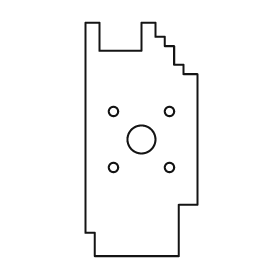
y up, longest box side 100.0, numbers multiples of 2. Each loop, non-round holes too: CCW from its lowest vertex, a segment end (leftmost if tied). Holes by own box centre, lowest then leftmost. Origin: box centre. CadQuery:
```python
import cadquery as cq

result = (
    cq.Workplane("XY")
    .moveTo(-20.0, -50.0)
    .lineTo(16.0, -50.0)
    .lineTo(16.0, -28.0)
    .lineTo(24.0, -28.0)
    .lineTo(24.0, 28.0)
    .lineTo(18.0, 28.0)
    .lineTo(18.0, 32.0)
    .lineTo(14.0, 32.0)
    .lineTo(14.0, 40.0)
    .lineTo(10.0, 40.0)
    .lineTo(10.0, 44.0)
    .lineTo(6.0, 44.0)
    .lineTo(6.0, 50.0)
    .lineTo(0.0, 50.0)
    .lineTo(0.0, 38.0)
    .lineTo(-18.0, 38.0)
    .lineTo(-18.0, 50.0)
    .lineTo(-24.0, 50.0)
    .lineTo(-24.0, -40.0)
    .lineTo(-20.0, -40.0)
    .close()
    .moveTo(-12.0, -12.0)
    .circle(2.0)
    .moveTo(12.0, -12.0)
    .circle(2.0)
    .moveTo(0.0, 0.0)
    .circle(6.0)
    .moveTo(-12.0, 12.0)
    .circle(2.0)
    .moveTo(12.0, 12.0)
    .circle(2.0)
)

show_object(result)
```